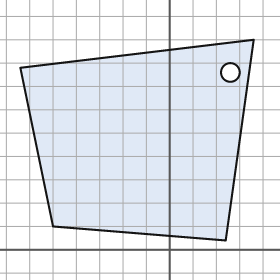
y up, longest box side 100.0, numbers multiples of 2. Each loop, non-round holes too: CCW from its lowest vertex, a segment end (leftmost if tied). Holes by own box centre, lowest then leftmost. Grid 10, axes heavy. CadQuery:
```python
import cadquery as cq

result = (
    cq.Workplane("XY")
    .moveTo(24.0, 4.0)
    .lineTo(36.0, 90.0)
    .lineTo(-64.0, 78.0)
    .lineTo(-50.0, 10.0)
    .close()
    .moveTo(26.0, 76.0)
    .circle(4.0)
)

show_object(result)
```